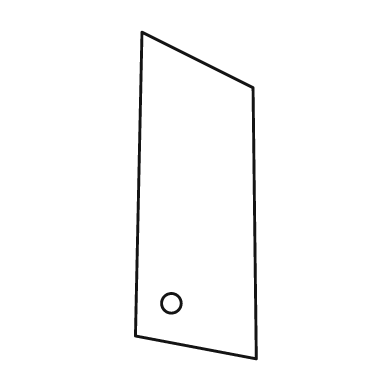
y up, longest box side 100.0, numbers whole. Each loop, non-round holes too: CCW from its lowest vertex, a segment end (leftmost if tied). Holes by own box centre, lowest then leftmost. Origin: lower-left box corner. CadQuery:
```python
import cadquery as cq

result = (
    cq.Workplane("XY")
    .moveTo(37.0, 0.0)
    .lineTo(36.0, 83.0)
    .lineTo(2.0, 100.0)
    .lineTo(0.0, 7.0)
    .close()
    .moveTo(11.0, 17.0)
    .circle(3.0)
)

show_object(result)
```